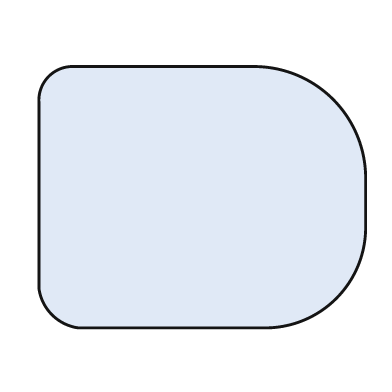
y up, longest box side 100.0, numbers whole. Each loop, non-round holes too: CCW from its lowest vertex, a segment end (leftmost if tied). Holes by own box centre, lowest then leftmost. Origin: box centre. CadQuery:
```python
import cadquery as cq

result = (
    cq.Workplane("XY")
    .moveTo(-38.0, -40.0)
    .lineTo(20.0, -40.0)
    .threePointArc((41.0, -31.0), (50.0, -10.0))
    .lineTo(50.0, 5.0)
    .threePointArc((40.0, 30.0), (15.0, 40.0))
    .lineTo(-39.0, 40.0)
    .threePointArc((-47.0, 37.0), (-50.0, 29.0))
    .lineTo(-50.0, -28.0)
    .threePointArc((-46.0, -36.0), (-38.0, -40.0))
    .close()
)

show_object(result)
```